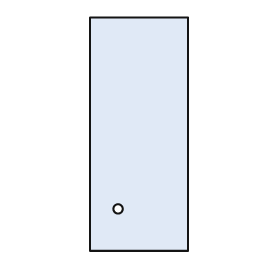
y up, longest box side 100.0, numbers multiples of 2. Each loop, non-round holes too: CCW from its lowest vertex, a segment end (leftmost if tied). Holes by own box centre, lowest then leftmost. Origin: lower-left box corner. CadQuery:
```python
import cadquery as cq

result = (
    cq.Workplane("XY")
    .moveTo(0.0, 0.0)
    .lineTo(42.0, 0.0)
    .lineTo(42.0, 100.0)
    .lineTo(0.0, 100.0)
    .close()
    .moveTo(12.0, 18.0)
    .circle(2.0)
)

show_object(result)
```